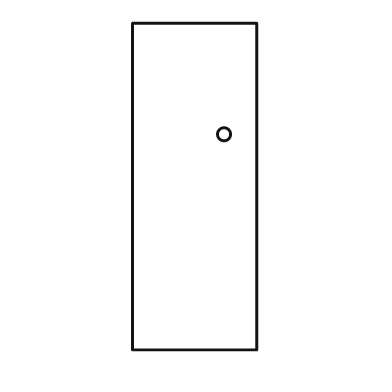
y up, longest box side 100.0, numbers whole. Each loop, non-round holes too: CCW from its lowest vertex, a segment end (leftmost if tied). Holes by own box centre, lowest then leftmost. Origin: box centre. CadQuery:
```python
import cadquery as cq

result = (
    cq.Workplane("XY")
    .moveTo(-19.0, -50.0)
    .lineTo(19.0, -50.0)
    .lineTo(19.0, 50.0)
    .lineTo(-19.0, 50.0)
    .close()
    .moveTo(9.0, 16.0)
    .circle(2.0)
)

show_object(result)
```